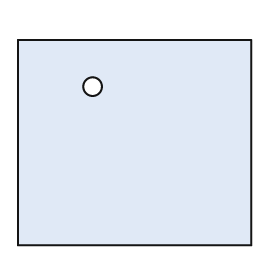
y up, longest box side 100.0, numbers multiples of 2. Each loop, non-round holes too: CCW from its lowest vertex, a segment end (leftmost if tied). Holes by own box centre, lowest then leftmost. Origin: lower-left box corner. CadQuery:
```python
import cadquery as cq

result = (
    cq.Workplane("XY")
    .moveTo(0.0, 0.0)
    .lineTo(100.0, 0.0)
    .lineTo(100.0, 88.0)
    .lineTo(0.0, 88.0)
    .close()
    .moveTo(32.0, 68.0)
    .circle(4.0)
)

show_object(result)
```